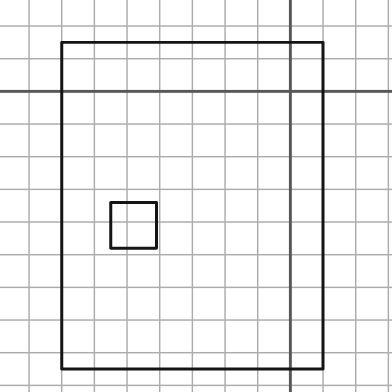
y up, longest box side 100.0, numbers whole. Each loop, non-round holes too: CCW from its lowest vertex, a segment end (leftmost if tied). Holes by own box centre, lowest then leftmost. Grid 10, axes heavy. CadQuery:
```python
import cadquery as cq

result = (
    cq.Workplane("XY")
    .moveTo(-70.0, -85.0)
    .lineTo(10.0, -85.0)
    .lineTo(10.0, 15.0)
    .lineTo(-70.0, 15.0)
    .close()
    .moveTo(-55.0, -48.0)
    .lineTo(-41.0, -48.0)
    .lineTo(-41.0, -34.0)
    .lineTo(-55.0, -34.0)
    .close()
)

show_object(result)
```